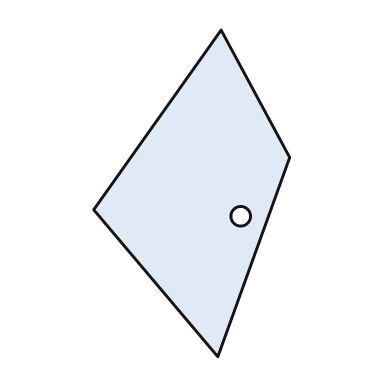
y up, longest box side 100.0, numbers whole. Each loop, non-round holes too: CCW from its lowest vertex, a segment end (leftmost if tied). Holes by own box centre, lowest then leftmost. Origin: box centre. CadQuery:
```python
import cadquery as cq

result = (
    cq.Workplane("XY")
    .moveTo(8.0, -50.0)
    .lineTo(30.0, 11.0)
    .lineTo(9.0, 50.0)
    .lineTo(-30.0, -5.0)
    .close()
    .moveTo(15.0, -7.0)
    .circle(3.0)
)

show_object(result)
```